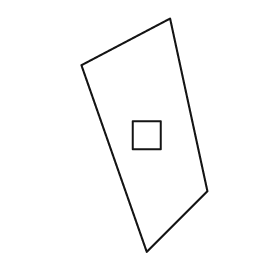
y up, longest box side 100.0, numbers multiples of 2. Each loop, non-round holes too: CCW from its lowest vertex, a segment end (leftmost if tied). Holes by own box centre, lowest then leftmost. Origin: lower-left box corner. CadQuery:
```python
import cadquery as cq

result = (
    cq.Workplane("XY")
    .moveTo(28.0, 0.0)
    .lineTo(54.0, 26.0)
    .lineTo(38.0, 100.0)
    .lineTo(0.0, 80.0)
    .close()
    .moveTo(22.0, 44.0)
    .lineTo(34.0, 44.0)
    .lineTo(34.0, 56.0)
    .lineTo(22.0, 56.0)
    .close()
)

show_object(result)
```